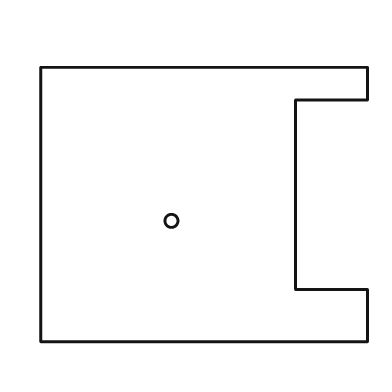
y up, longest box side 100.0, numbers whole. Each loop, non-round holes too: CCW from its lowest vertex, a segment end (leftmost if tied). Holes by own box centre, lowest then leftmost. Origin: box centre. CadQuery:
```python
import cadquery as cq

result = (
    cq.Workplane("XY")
    .moveTo(-50.0, -42.0)
    .lineTo(50.0, -42.0)
    .lineTo(50.0, -26.0)
    .lineTo(28.0, -26.0)
    .lineTo(28.0, 32.0)
    .lineTo(50.0, 32.0)
    .lineTo(50.0, 42.0)
    .lineTo(-50.0, 42.0)
    .close()
    .moveTo(-10.0, -5.0)
    .circle(2.0)
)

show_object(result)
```